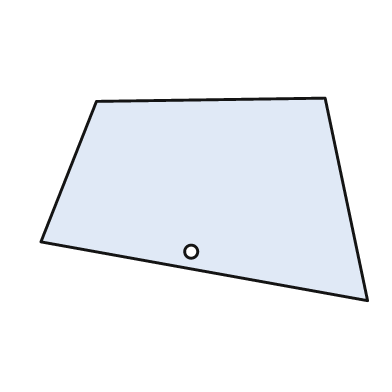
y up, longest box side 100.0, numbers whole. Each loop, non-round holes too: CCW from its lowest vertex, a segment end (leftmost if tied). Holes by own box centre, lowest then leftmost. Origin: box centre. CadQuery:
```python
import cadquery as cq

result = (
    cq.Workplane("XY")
    .moveTo(50.0, -31.0)
    .lineTo(37.0, 31.0)
    .lineTo(-33.0, 30.0)
    .lineTo(-50.0, -13.0)
    .close()
    .moveTo(-4.0, -16.0)
    .circle(2.0)
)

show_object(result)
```